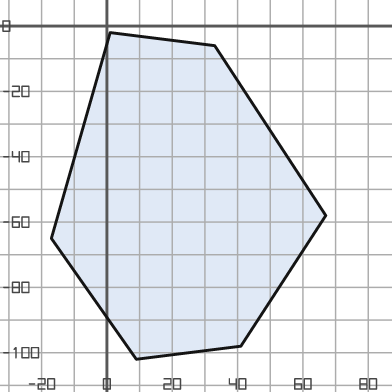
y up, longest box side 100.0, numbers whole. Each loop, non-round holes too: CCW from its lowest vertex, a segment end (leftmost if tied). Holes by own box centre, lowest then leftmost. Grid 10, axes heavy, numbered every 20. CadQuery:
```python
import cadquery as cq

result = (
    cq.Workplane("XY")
    .moveTo(9.0, -102.0)
    .lineTo(41.0, -98.0)
    .lineTo(67.0, -58.0)
    .lineTo(33.0, -6.0)
    .lineTo(1.0, -2.0)
    .lineTo(-17.0, -65.0)
    .close()
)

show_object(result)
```